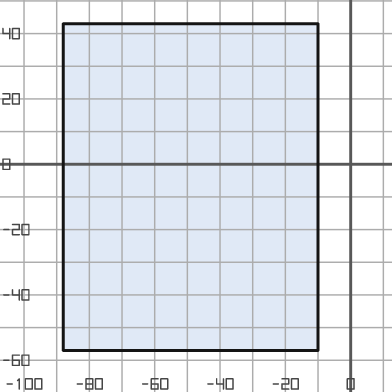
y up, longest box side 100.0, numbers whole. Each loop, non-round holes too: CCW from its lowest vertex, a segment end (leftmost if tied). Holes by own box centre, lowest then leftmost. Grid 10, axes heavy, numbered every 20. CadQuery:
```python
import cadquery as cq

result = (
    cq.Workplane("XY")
    .moveTo(-88.0, -57.0)
    .lineTo(-10.0, -57.0)
    .lineTo(-10.0, 43.0)
    .lineTo(-88.0, 43.0)
    .close()
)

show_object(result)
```